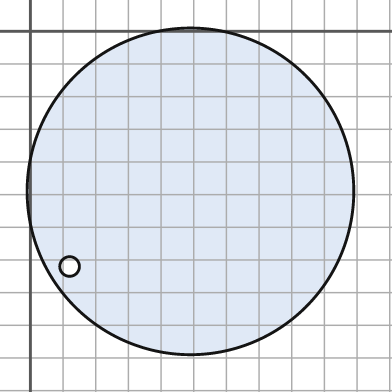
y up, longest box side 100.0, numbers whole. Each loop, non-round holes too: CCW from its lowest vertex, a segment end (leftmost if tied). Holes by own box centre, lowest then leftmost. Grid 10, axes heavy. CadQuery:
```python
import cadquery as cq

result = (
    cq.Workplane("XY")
    .moveTo(49.0, -49.0)
    .circle(50.0)
    .moveTo(12.0, -72.0)
    .circle(3.0)
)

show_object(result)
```